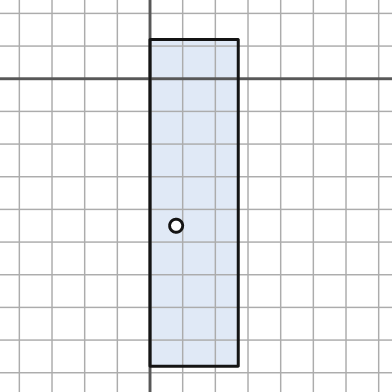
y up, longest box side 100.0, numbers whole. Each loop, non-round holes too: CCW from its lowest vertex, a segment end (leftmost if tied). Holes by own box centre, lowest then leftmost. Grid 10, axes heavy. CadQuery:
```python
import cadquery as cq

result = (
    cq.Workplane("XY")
    .moveTo(0.0, -88.0)
    .lineTo(27.0, -88.0)
    .lineTo(27.0, 12.0)
    .lineTo(0.0, 12.0)
    .close()
    .moveTo(8.0, -45.0)
    .circle(2.0)
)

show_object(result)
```